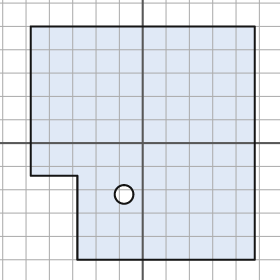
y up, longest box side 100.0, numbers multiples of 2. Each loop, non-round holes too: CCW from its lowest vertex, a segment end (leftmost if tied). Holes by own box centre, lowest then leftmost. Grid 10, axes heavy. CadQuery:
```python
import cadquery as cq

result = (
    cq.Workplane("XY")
    .moveTo(-28.0, -50.0)
    .lineTo(48.0, -50.0)
    .lineTo(48.0, 50.0)
    .lineTo(-48.0, 50.0)
    .lineTo(-48.0, -14.0)
    .lineTo(-28.0, -14.0)
    .close()
    .moveTo(-8.0, -22.0)
    .circle(4.0)
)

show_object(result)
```